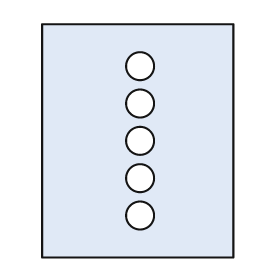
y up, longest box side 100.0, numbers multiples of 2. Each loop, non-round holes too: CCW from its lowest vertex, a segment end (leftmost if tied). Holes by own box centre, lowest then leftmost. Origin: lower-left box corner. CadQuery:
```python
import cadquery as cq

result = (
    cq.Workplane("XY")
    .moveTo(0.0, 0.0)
    .lineTo(82.0, 0.0)
    .lineTo(82.0, 100.0)
    .lineTo(0.0, 100.0)
    .close()
    .moveTo(42.0, 18.0)
    .circle(6.0)
    .moveTo(42.0, 34.0)
    .circle(6.0)
    .moveTo(42.0, 50.0)
    .circle(6.0)
    .moveTo(42.0, 66.0)
    .circle(6.0)
    .moveTo(42.0, 82.0)
    .circle(6.0)
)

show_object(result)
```